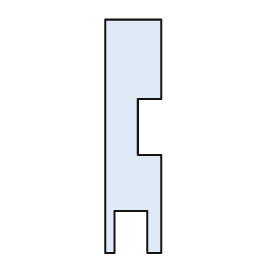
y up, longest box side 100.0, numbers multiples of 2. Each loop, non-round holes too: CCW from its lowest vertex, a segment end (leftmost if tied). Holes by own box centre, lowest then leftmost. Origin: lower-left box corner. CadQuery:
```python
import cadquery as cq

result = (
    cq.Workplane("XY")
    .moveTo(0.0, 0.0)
    .lineTo(4.0, 0.0)
    .lineTo(4.0, 18.0)
    .lineTo(18.0, 18.0)
    .lineTo(18.0, 0.0)
    .lineTo(24.0, 0.0)
    .lineTo(24.0, 42.0)
    .lineTo(14.0, 42.0)
    .lineTo(14.0, 66.0)
    .lineTo(24.0, 66.0)
    .lineTo(24.0, 100.0)
    .lineTo(0.0, 100.0)
    .close()
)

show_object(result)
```